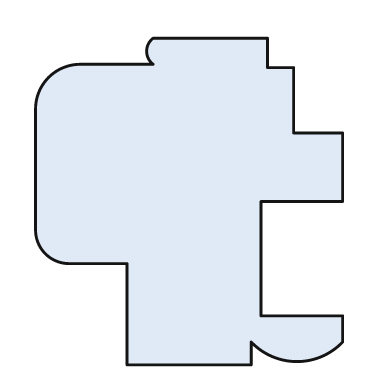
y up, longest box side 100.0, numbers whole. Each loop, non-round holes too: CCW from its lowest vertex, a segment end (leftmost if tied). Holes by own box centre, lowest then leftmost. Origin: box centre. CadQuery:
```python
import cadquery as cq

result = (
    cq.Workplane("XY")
    .moveTo(-19.0, -50.0)
    .lineTo(19.0, -50.0)
    .lineTo(19.0, -43.0)
    .threePointArc((33.0, -49.0), (47.0, -43.0))
    .lineTo(47.0, -35.0)
    .lineTo(22.0, -35.0)
    .lineTo(22.0, 0.0)
    .lineTo(47.0, 0.0)
    .lineTo(47.0, 21.0)
    .lineTo(32.0, 21.0)
    .lineTo(32.0, 41.0)
    .lineTo(24.0, 41.0)
    .lineTo(24.0, 50.0)
    .lineTo(-11.0, 50.0)
    .threePointArc((-13.0, 46.0), (-11.0, 42.0))
    .lineTo(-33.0, 42.0)
    .threePointArc((-43.0, 38.0), (-47.0, 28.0))
    .lineTo(-47.0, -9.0)
    .threePointArc((-44.0, -16.0), (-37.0, -19.0))
    .lineTo(-19.0, -19.0)
    .close()
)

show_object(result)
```